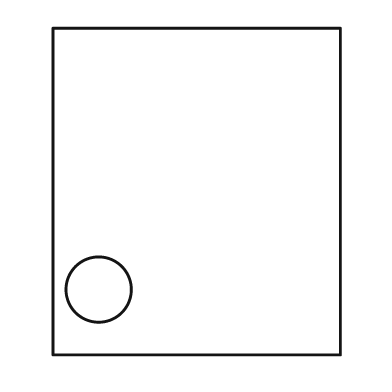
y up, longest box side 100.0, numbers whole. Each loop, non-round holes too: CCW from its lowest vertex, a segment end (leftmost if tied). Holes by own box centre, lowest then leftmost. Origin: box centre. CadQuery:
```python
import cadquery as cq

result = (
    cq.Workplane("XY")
    .moveTo(-44.0, -50.0)
    .lineTo(44.0, -50.0)
    .lineTo(44.0, 50.0)
    .lineTo(-44.0, 50.0)
    .close()
    .moveTo(-30.0, -30.0)
    .circle(10.0)
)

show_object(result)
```